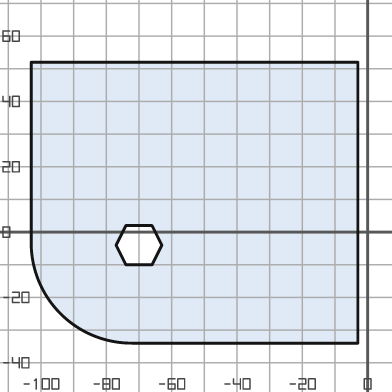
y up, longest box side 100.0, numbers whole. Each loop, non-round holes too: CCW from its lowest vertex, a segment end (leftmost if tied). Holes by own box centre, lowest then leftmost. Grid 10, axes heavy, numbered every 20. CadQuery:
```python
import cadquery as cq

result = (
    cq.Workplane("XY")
    .moveTo(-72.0, -34.0)
    .lineTo(-3.0, -34.0)
    .lineTo(-3.0, 52.0)
    .lineTo(-103.0, 52.0)
    .lineTo(-103.0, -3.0)
    .threePointArc((-94.0, -25.0), (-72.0, -34.0))
    .close()
    .moveTo(-74.0, -10.0)
    .lineTo(-66.0, -10.0)
    .lineTo(-63.0, -4.0)
    .lineTo(-66.0, 2.0)
    .lineTo(-74.0, 2.0)
    .lineTo(-77.0, -4.0)
    .close()
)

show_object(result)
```